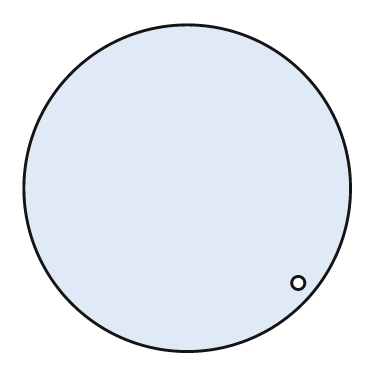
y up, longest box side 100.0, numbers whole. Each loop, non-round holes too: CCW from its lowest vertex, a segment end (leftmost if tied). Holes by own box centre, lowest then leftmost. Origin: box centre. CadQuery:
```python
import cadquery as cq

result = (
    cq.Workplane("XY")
    .moveTo(0.0, 0.0)
    .circle(50.0)
    .moveTo(34.0, -29.0)
    .circle(2.0)
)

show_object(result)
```